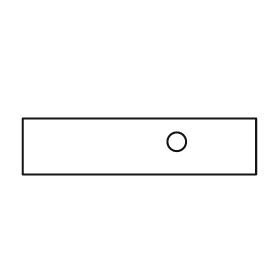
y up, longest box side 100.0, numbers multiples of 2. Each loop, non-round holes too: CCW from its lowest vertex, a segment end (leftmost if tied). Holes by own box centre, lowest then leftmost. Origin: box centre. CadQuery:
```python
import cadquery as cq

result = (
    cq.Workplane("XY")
    .moveTo(-50.0, -12.0)
    .lineTo(50.0, -12.0)
    .lineTo(50.0, 12.0)
    .lineTo(-50.0, 12.0)
    .close()
    .moveTo(16.0, 2.0)
    .circle(4.0)
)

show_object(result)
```